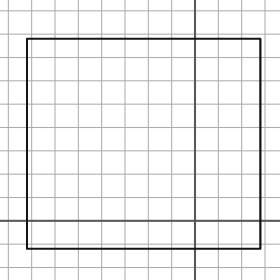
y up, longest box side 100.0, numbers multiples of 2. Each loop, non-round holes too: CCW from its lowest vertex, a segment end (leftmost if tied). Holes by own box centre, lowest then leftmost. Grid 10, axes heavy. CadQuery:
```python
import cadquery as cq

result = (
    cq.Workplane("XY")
    .moveTo(-72.0, -12.0)
    .lineTo(28.0, -12.0)
    .lineTo(28.0, 78.0)
    .lineTo(-72.0, 78.0)
    .close()
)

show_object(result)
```